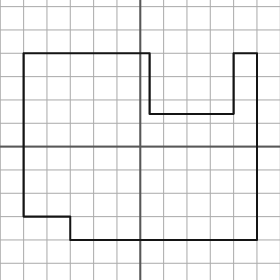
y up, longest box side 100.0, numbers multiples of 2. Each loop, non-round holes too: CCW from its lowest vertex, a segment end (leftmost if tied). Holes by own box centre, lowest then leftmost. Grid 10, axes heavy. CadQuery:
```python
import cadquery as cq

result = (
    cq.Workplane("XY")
    .moveTo(-30.0, -40.0)
    .lineTo(50.0, -40.0)
    .lineTo(50.0, 40.0)
    .lineTo(40.0, 40.0)
    .lineTo(40.0, 14.0)
    .lineTo(4.0, 14.0)
    .lineTo(4.0, 40.0)
    .lineTo(-50.0, 40.0)
    .lineTo(-50.0, -30.0)
    .lineTo(-30.0, -30.0)
    .close()
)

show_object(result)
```